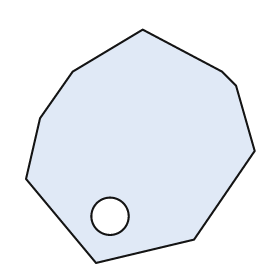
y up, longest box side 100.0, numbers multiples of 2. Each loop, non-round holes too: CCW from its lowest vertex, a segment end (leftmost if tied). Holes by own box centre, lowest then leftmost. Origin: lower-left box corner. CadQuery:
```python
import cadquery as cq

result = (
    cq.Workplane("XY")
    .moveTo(30.0, 0.0)
    .lineTo(72.0, 10.0)
    .lineTo(98.0, 48.0)
    .lineTo(90.0, 76.0)
    .lineTo(84.0, 82.0)
    .lineTo(50.0, 100.0)
    .lineTo(20.0, 82.0)
    .lineTo(6.0, 62.0)
    .lineTo(0.0, 36.0)
    .close()
    .moveTo(36.0, 20.0)
    .circle(8.0)
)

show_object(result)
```